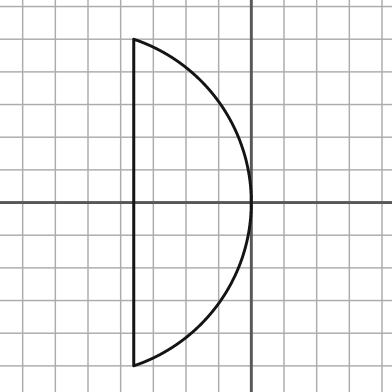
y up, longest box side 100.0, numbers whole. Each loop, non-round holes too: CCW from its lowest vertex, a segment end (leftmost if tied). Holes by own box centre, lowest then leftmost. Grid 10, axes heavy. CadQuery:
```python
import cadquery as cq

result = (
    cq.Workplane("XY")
    .moveTo(-36.0, -50.0)
    .threePointArc((0.0, 0.0), (-36.0, 50.0))
    .close()
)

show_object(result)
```